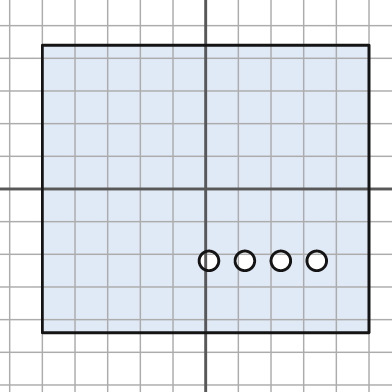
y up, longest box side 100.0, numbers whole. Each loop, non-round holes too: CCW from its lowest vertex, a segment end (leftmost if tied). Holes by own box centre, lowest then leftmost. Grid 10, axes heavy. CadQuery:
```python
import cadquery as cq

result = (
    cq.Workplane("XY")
    .moveTo(-50.0, -44.0)
    .lineTo(50.0, -44.0)
    .lineTo(50.0, 44.0)
    .lineTo(-50.0, 44.0)
    .close()
    .moveTo(1.0, -22.0)
    .circle(3.0)
    .moveTo(12.0, -22.0)
    .circle(3.0)
    .moveTo(23.0, -22.0)
    .circle(3.0)
    .moveTo(34.0, -22.0)
    .circle(3.0)
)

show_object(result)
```